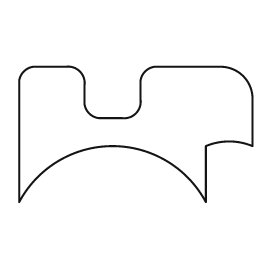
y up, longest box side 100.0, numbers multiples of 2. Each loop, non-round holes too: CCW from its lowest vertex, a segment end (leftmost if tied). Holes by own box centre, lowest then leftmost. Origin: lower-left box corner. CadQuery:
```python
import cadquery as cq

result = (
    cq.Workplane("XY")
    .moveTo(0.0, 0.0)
    .threePointArc((40.0, 24.0), (80.0, 0.0))
    .lineTo(80.0, 24.0)
    .threePointArc((90.0, 26.0), (100.0, 24.0))
    .lineTo(100.0, 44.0)
    .threePointArc((96.0, 54.0), (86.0, 58.0))
    .lineTo(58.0, 58.0)
    .threePointArc((54.0, 56.0), (52.0, 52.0))
    .lineTo(52.0, 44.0)
    .threePointArc((50.0, 38.0), (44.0, 36.0))
    .lineTo(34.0, 36.0)
    .threePointArc((30.0, 38.0), (28.0, 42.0))
    .lineTo(28.0, 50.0)
    .threePointArc((26.0, 56.0), (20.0, 58.0))
    .lineTo(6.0, 58.0)
    .threePointArc((2.0, 56.0), (0.0, 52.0))
    .close()
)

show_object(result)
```